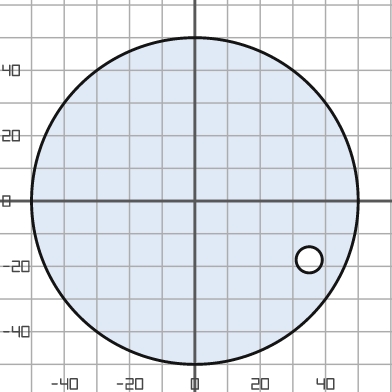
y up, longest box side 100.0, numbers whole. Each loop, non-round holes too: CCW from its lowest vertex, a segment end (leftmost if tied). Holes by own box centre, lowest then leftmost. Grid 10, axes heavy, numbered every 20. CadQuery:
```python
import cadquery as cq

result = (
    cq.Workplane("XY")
    .moveTo(0.0, 0.0)
    .circle(50.0)
    .moveTo(35.0, -18.0)
    .circle(4.0)
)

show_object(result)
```